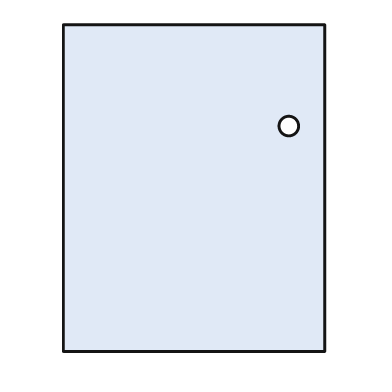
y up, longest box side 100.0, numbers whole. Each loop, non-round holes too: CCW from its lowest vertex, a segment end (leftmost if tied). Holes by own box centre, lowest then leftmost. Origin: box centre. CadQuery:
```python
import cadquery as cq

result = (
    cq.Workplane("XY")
    .moveTo(-40.0, -50.0)
    .lineTo(40.0, -50.0)
    .lineTo(40.0, 50.0)
    .lineTo(-40.0, 50.0)
    .close()
    .moveTo(29.0, 19.0)
    .circle(3.0)
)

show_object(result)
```